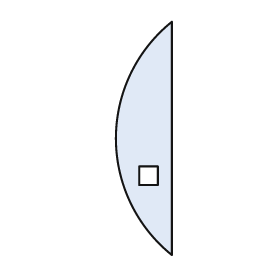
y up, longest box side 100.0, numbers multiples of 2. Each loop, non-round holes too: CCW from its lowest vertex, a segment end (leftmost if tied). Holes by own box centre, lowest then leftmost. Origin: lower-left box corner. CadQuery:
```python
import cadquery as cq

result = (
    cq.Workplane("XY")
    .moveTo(24.0, 0.0)
    .lineTo(24.0, 100.0)
    .threePointArc((0.0, 50.0), (24.0, 0.0))
    .close()
    .moveTo(10.0, 30.0)
    .lineTo(18.0, 30.0)
    .lineTo(18.0, 38.0)
    .lineTo(10.0, 38.0)
    .close()
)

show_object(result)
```